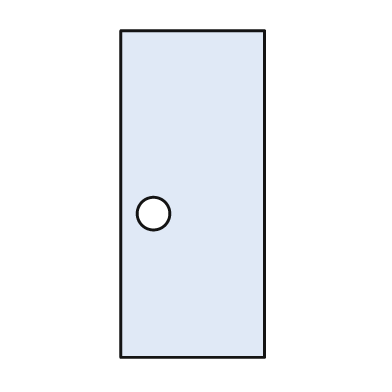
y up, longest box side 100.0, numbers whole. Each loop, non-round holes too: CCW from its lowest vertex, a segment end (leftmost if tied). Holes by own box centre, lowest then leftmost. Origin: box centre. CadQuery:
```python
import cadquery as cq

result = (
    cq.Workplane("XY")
    .moveTo(-22.0, -50.0)
    .lineTo(22.0, -50.0)
    .lineTo(22.0, 50.0)
    .lineTo(-22.0, 50.0)
    .close()
    .moveTo(-12.0, -6.0)
    .circle(5.0)
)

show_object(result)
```